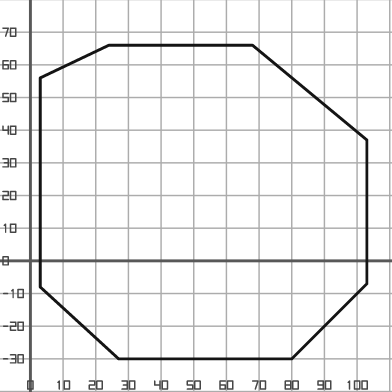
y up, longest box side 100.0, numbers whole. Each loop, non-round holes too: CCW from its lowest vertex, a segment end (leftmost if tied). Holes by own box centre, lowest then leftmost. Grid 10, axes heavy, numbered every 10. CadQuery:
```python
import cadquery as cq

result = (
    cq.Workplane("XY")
    .moveTo(27.0, -30.0)
    .lineTo(80.0, -30.0)
    .lineTo(103.0, -7.0)
    .lineTo(103.0, 37.0)
    .lineTo(68.0, 66.0)
    .lineTo(24.0, 66.0)
    .lineTo(3.0, 56.0)
    .lineTo(3.0, -8.0)
    .close()
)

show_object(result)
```